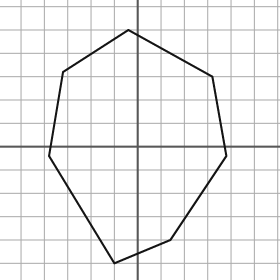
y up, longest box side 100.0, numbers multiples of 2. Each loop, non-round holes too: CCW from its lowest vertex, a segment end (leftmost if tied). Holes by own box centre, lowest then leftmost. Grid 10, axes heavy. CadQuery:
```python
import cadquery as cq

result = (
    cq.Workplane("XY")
    .moveTo(-10.0, -50.0)
    .lineTo(14.0, -40.0)
    .lineTo(38.0, -4.0)
    .lineTo(32.0, 30.0)
    .lineTo(-4.0, 50.0)
    .lineTo(-32.0, 32.0)
    .lineTo(-38.0, -4.0)
    .close()
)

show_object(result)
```